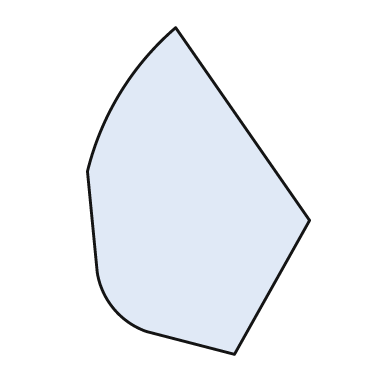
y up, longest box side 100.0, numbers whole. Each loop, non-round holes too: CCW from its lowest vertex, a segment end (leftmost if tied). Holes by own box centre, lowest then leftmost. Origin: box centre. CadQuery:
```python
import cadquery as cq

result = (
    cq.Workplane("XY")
    .moveTo(11.0, -50.0)
    .lineTo(34.0, -9.0)
    .lineTo(-7.0, 50.0)
    .threePointArc((-24.0, 30.0), (-34.0, 6.0))
    .lineTo(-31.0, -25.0)
    .threePointArc((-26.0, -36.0), (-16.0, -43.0))
    .close()
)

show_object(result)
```